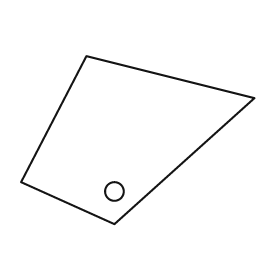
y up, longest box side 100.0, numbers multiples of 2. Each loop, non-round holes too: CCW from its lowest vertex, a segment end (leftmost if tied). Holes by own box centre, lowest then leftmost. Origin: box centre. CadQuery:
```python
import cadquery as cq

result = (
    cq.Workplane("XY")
    .moveTo(-10.0, -36.0)
    .lineTo(50.0, 18.0)
    .lineTo(-22.0, 36.0)
    .lineTo(-50.0, -18.0)
    .close()
    .moveTo(-10.0, -22.0)
    .circle(4.0)
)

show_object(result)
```